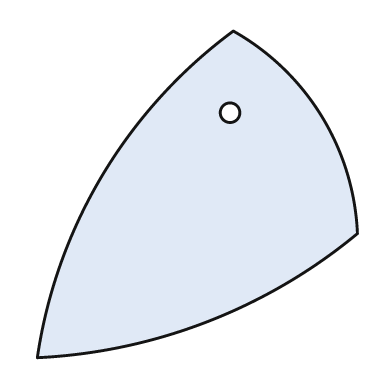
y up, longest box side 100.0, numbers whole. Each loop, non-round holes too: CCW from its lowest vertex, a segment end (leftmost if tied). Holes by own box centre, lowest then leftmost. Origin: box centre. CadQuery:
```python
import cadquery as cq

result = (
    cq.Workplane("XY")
    .moveTo(-49.0, -50.0)
    .threePointArc((3.0, -39.0), (49.0, -12.0))
    .threePointArc((38.0, 24.0), (11.0, 50.0))
    .threePointArc((-29.0, 6.0), (-49.0, -50.0))
    .close()
    .moveTo(10.0, 25.0)
    .circle(3.0)
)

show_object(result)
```